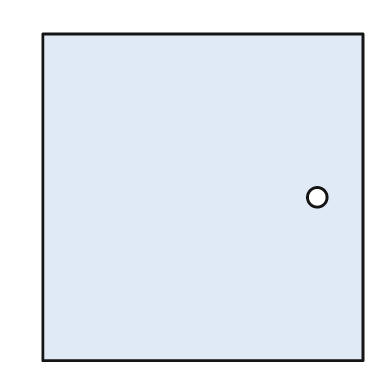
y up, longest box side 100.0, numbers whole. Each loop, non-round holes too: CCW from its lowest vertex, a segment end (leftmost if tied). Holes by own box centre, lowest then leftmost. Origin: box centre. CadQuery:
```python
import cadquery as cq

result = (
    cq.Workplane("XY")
    .moveTo(-49.0, -50.0)
    .lineTo(49.0, -50.0)
    .lineTo(49.0, 50.0)
    .lineTo(-49.0, 50.0)
    .close()
    .moveTo(35.0, 0.0)
    .circle(3.0)
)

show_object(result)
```